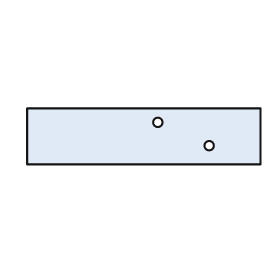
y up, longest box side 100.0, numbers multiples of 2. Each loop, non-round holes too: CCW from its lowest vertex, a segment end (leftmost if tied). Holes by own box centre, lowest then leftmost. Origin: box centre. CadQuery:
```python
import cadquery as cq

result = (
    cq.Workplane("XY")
    .moveTo(-50.0, -12.0)
    .lineTo(50.0, -12.0)
    .lineTo(50.0, 12.0)
    .lineTo(-50.0, 12.0)
    .close()
    .moveTo(28.0, -4.0)
    .circle(2.0)
    .moveTo(6.0, 6.0)
    .circle(2.0)
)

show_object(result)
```